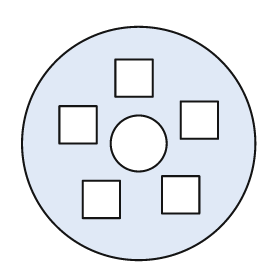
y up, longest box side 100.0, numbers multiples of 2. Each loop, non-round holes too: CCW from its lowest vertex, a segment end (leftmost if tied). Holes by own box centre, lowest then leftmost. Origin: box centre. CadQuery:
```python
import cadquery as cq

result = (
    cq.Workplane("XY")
    .moveTo(0.0, 0.0)
    .circle(50.0)
    .moveTo(-24.0, -32.0)
    .lineTo(-8.0, -32.0)
    .lineTo(-8.0, -16.0)
    .lineTo(-24.0, -16.0)
    .close()
    .moveTo(10.0, -30.0)
    .lineTo(26.0, -30.0)
    .lineTo(26.0, -14.0)
    .lineTo(10.0, -14.0)
    .close()
    .moveTo(0.0, 0.0)
    .circle(12.0)
    .moveTo(-34.0, 0.0)
    .lineTo(-18.0, 0.0)
    .lineTo(-18.0, 16.0)
    .lineTo(-34.0, 16.0)
    .close()
    .moveTo(18.0, 2.0)
    .lineTo(34.0, 2.0)
    .lineTo(34.0, 18.0)
    .lineTo(18.0, 18.0)
    .close()
    .moveTo(-10.0, 20.0)
    .lineTo(6.0, 20.0)
    .lineTo(6.0, 36.0)
    .lineTo(-10.0, 36.0)
    .close()
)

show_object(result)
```